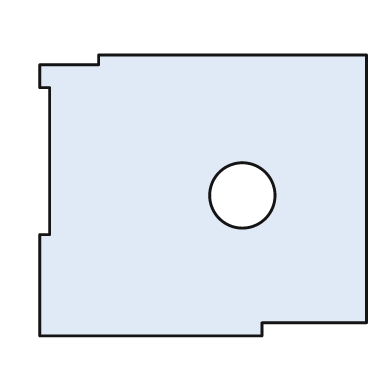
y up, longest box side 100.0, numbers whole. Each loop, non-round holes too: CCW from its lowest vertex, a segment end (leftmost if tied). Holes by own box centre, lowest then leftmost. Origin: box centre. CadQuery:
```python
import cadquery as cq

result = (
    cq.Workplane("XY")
    .moveTo(-50.0, -43.0)
    .lineTo(18.0, -43.0)
    .lineTo(18.0, -39.0)
    .lineTo(50.0, -39.0)
    .lineTo(50.0, 43.0)
    .lineTo(-32.0, 43.0)
    .lineTo(-32.0, 40.0)
    .lineTo(-50.0, 40.0)
    .lineTo(-50.0, 33.0)
    .lineTo(-47.0, 33.0)
    .lineTo(-47.0, -12.0)
    .lineTo(-50.0, -12.0)
    .close()
    .moveTo(12.0, 0.0)
    .circle(10.0)
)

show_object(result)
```